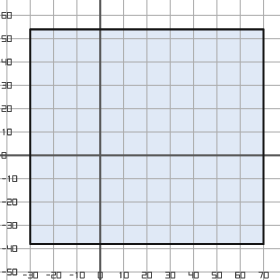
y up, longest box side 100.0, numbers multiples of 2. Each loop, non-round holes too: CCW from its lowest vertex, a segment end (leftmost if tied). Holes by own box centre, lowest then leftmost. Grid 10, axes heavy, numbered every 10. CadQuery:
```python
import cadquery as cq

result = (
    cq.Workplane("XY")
    .moveTo(-30.0, -38.0)
    .lineTo(70.0, -38.0)
    .lineTo(70.0, 54.0)
    .lineTo(-30.0, 54.0)
    .close()
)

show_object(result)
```